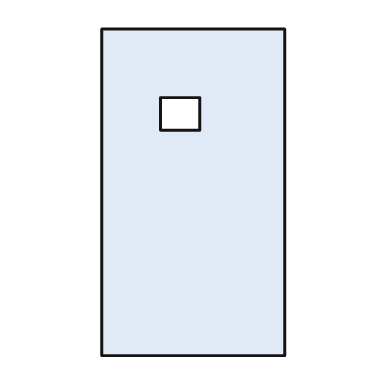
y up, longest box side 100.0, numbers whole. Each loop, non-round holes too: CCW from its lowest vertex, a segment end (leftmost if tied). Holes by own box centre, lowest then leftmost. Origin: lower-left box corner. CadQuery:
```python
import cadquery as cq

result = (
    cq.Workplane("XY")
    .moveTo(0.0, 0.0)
    .lineTo(56.0, 0.0)
    .lineTo(56.0, 100.0)
    .lineTo(0.0, 100.0)
    .close()
    .moveTo(18.0, 69.0)
    .lineTo(30.0, 69.0)
    .lineTo(30.0, 79.0)
    .lineTo(18.0, 79.0)
    .close()
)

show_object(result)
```